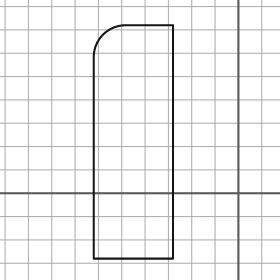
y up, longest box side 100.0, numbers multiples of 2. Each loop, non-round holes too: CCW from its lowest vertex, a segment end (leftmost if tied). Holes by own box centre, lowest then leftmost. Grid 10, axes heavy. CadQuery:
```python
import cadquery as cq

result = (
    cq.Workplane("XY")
    .moveTo(-62.0, -28.0)
    .lineTo(-28.0, -28.0)
    .lineTo(-28.0, 72.0)
    .lineTo(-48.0, 72.0)
    .threePointArc((-58.0, 68.0), (-62.0, 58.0))
    .close()
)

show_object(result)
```